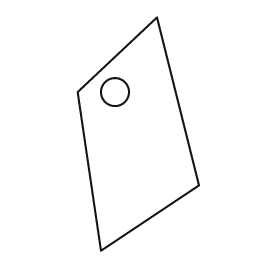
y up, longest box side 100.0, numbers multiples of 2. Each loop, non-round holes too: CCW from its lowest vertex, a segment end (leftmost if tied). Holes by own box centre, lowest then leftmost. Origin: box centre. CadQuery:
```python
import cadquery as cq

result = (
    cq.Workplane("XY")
    .moveTo(-16.0, -50.0)
    .lineTo(26.0, -22.0)
    .lineTo(8.0, 50.0)
    .lineTo(-26.0, 18.0)
    .close()
    .moveTo(-10.0, 18.0)
    .circle(6.0)
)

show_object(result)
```